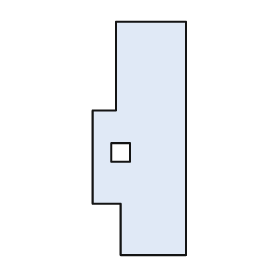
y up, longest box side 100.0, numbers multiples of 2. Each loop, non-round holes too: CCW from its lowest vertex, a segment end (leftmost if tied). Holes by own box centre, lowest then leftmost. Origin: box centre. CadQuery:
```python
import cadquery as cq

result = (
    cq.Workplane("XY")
    .moveTo(-8.0, -50.0)
    .lineTo(20.0, -50.0)
    .lineTo(20.0, 50.0)
    .lineTo(-10.0, 50.0)
    .lineTo(-10.0, 12.0)
    .lineTo(-20.0, 12.0)
    .lineTo(-20.0, -28.0)
    .lineTo(-8.0, -28.0)
    .close()
    .moveTo(-12.0, -10.0)
    .lineTo(-4.0, -10.0)
    .lineTo(-4.0, -2.0)
    .lineTo(-12.0, -2.0)
    .close()
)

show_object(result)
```